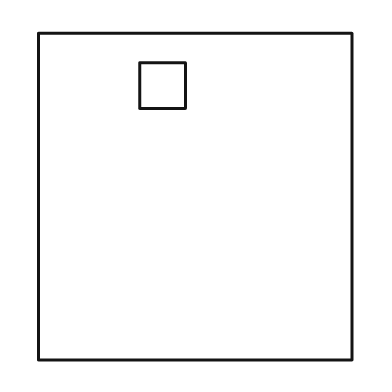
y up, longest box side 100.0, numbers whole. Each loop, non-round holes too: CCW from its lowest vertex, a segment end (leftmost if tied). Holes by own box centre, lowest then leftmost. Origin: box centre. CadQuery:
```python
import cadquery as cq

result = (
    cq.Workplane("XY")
    .moveTo(-48.0, -50.0)
    .lineTo(48.0, -50.0)
    .lineTo(48.0, 50.0)
    .lineTo(-48.0, 50.0)
    .close()
    .moveTo(-17.0, 27.0)
    .lineTo(-3.0, 27.0)
    .lineTo(-3.0, 41.0)
    .lineTo(-17.0, 41.0)
    .close()
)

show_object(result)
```